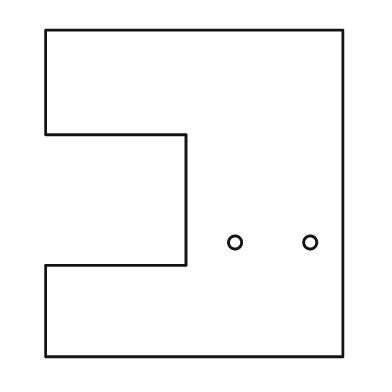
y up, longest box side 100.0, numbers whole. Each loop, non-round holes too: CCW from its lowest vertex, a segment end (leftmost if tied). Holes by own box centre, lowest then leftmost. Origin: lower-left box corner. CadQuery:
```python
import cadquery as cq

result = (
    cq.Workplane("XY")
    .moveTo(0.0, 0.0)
    .lineTo(91.0, 0.0)
    .lineTo(91.0, 100.0)
    .lineTo(0.0, 100.0)
    .lineTo(0.0, 68.0)
    .lineTo(43.0, 68.0)
    .lineTo(43.0, 28.0)
    .lineTo(0.0, 28.0)
    .close()
    .moveTo(58.0, 35.0)
    .circle(2.0)
    .moveTo(81.0, 35.0)
    .circle(2.0)
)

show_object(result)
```